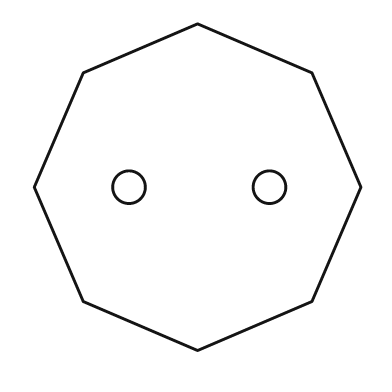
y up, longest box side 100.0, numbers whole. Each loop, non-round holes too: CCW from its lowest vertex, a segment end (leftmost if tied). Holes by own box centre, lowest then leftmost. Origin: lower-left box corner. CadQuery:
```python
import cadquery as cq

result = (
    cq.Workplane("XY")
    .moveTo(50.0, 0.0)
    .lineTo(85.0, 15.0)
    .lineTo(100.0, 50.0)
    .lineTo(85.0, 85.0)
    .lineTo(50.0, 100.0)
    .lineTo(15.0, 85.0)
    .lineTo(0.0, 50.0)
    .lineTo(15.0, 15.0)
    .close()
    .moveTo(29.0, 50.0)
    .circle(5.0)
    .moveTo(72.0, 50.0)
    .circle(5.0)
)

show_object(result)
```